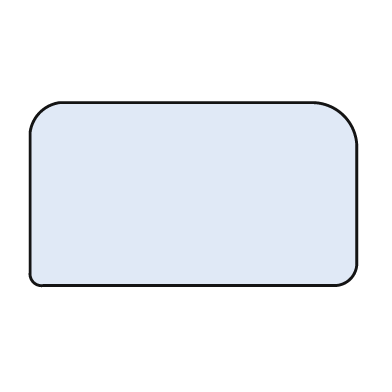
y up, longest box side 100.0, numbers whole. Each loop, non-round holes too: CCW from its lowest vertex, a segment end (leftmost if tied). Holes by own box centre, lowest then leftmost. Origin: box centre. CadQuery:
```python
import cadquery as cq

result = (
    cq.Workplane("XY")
    .moveTo(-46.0, -28.0)
    .lineTo(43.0, -28.0)
    .threePointArc((48.0, -26.0), (50.0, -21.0))
    .lineTo(50.0, 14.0)
    .threePointArc((46.0, 24.0), (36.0, 28.0))
    .lineTo(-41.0, 28.0)
    .threePointArc((-47.0, 25.0), (-50.0, 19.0))
    .lineTo(-50.0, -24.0)
    .threePointArc((-49.0, -27.0), (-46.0, -28.0))
    .close()
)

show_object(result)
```